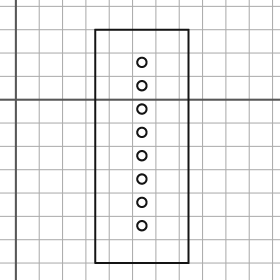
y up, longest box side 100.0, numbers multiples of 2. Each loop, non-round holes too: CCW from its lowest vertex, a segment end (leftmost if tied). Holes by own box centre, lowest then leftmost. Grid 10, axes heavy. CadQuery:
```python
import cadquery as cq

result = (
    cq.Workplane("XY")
    .moveTo(34.0, -70.0)
    .lineTo(74.0, -70.0)
    .lineTo(74.0, 30.0)
    .lineTo(34.0, 30.0)
    .close()
    .moveTo(54.0, -54.0)
    .circle(2.0)
    .moveTo(54.0, -44.0)
    .circle(2.0)
    .moveTo(54.0, -34.0)
    .circle(2.0)
    .moveTo(54.0, -24.0)
    .circle(2.0)
    .moveTo(54.0, -14.0)
    .circle(2.0)
    .moveTo(54.0, -4.0)
    .circle(2.0)
    .moveTo(54.0, 6.0)
    .circle(2.0)
    .moveTo(54.0, 16.0)
    .circle(2.0)
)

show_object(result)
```